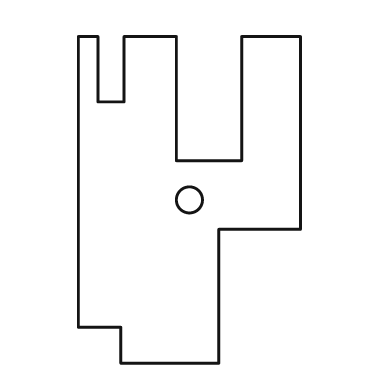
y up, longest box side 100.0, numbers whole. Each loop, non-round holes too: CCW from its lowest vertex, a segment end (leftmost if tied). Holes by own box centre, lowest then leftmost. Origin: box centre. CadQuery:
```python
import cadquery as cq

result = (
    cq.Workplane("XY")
    .moveTo(-21.0, -50.0)
    .lineTo(9.0, -50.0)
    .lineTo(9.0, -9.0)
    .lineTo(34.0, -9.0)
    .lineTo(34.0, 50.0)
    .lineTo(16.0, 50.0)
    .lineTo(16.0, 12.0)
    .lineTo(-4.0, 12.0)
    .lineTo(-4.0, 50.0)
    .lineTo(-20.0, 50.0)
    .lineTo(-20.0, 30.0)
    .lineTo(-28.0, 30.0)
    .lineTo(-28.0, 50.0)
    .lineTo(-34.0, 50.0)
    .lineTo(-34.0, -39.0)
    .lineTo(-21.0, -39.0)
    .close()
    .moveTo(0.0, 0.0)
    .circle(4.0)
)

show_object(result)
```